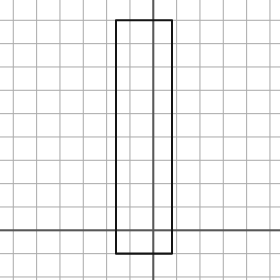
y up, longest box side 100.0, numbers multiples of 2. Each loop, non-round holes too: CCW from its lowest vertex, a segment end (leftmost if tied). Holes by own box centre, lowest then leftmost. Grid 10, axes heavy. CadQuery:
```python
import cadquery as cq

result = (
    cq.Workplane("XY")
    .moveTo(-16.0, -10.0)
    .lineTo(8.0, -10.0)
    .lineTo(8.0, 90.0)
    .lineTo(-16.0, 90.0)
    .close()
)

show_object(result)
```